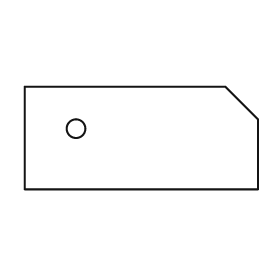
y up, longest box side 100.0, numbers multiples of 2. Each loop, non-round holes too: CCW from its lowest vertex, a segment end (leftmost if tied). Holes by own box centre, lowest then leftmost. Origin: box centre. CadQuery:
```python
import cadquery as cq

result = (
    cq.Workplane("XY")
    .moveTo(-50.0, -22.0)
    .lineTo(50.0, -22.0)
    .lineTo(50.0, 8.0)
    .lineTo(36.0, 22.0)
    .lineTo(-50.0, 22.0)
    .close()
    .moveTo(-28.0, 4.0)
    .circle(4.0)
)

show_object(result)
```